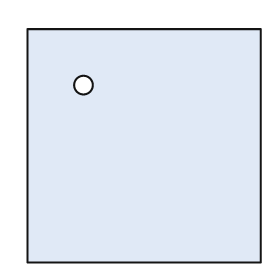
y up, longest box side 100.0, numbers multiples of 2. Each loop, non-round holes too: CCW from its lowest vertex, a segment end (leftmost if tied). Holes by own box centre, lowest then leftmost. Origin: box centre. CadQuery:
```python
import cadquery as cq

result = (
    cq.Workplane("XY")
    .moveTo(-50.0, -50.0)
    .lineTo(50.0, -50.0)
    .lineTo(50.0, 50.0)
    .lineTo(-50.0, 50.0)
    .close()
    .moveTo(-26.0, 26.0)
    .circle(4.0)
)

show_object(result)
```